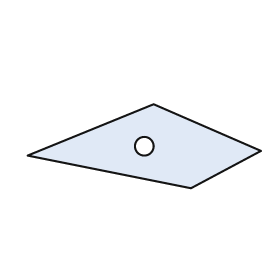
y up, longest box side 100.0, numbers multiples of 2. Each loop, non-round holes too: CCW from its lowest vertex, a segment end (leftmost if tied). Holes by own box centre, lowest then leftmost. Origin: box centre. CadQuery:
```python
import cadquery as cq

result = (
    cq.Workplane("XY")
    .moveTo(20.0, -18.0)
    .lineTo(50.0, -2.0)
    .lineTo(4.0, 18.0)
    .lineTo(-50.0, -4.0)
    .close()
    .moveTo(0.0, 0.0)
    .circle(4.0)
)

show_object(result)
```